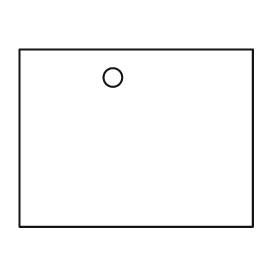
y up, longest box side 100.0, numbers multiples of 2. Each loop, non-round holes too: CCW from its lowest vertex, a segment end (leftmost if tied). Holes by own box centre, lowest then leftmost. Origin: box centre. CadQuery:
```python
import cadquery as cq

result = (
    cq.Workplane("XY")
    .moveTo(-50.0, -38.0)
    .lineTo(50.0, -38.0)
    .lineTo(50.0, 38.0)
    .lineTo(-50.0, 38.0)
    .close()
    .moveTo(-10.0, 26.0)
    .circle(4.0)
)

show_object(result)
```